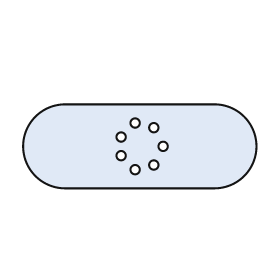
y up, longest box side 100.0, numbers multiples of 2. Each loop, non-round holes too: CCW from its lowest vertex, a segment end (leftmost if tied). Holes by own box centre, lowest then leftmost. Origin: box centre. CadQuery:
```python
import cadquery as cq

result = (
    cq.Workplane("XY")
    .moveTo(-32.0, -18.0)
    .lineTo(32.0, -18.0)
    .threePointArc((50.0, 0.0), (32.0, 18.0))
    .lineTo(-32.0, 18.0)
    .threePointArc((-50.0, 0.0), (-32.0, -18.0))
    .close()
    .moveTo(-2.0, -10.0)
    .circle(2.0)
    .moveTo(6.0, -8.0)
    .circle(2.0)
    .moveTo(-8.0, -4.0)
    .circle(2.0)
    .moveTo(10.0, 0.0)
    .circle(2.0)
    .moveTo(-8.0, 4.0)
    .circle(2.0)
    .moveTo(6.0, 8.0)
    .circle(2.0)
    .moveTo(-2.0, 10.0)
    .circle(2.0)
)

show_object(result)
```